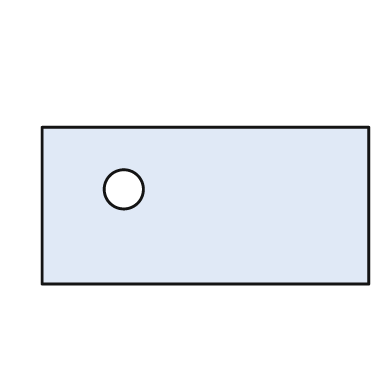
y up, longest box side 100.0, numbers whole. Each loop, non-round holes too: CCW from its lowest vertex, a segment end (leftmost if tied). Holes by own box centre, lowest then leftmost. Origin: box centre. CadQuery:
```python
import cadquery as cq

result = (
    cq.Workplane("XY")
    .moveTo(-50.0, -24.0)
    .lineTo(50.0, -24.0)
    .lineTo(50.0, 24.0)
    .lineTo(-50.0, 24.0)
    .close()
    .moveTo(-25.0, 5.0)
    .circle(6.0)
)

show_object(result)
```